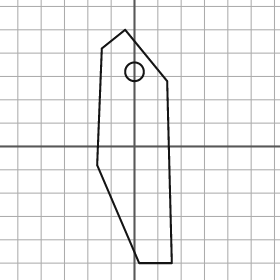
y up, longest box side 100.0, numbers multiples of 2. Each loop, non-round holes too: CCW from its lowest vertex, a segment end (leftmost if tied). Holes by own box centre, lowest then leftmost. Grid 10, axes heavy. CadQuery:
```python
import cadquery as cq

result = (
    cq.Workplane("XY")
    .moveTo(2.0, -50.0)
    .lineTo(16.0, -50.0)
    .lineTo(14.0, 28.0)
    .lineTo(-4.0, 50.0)
    .lineTo(-14.0, 42.0)
    .lineTo(-16.0, -8.0)
    .close()
    .moveTo(0.0, 32.0)
    .circle(4.0)
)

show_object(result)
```